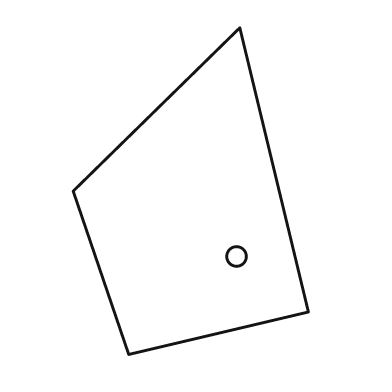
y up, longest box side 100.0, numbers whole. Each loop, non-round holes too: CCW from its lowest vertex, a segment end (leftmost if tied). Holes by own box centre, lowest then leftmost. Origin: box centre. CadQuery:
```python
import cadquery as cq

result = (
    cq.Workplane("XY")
    .moveTo(-19.0, -50.0)
    .lineTo(36.0, -37.0)
    .lineTo(15.0, 50.0)
    .lineTo(-36.0, 0.0)
    .close()
    .moveTo(14.0, -20.0)
    .circle(3.0)
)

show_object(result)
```